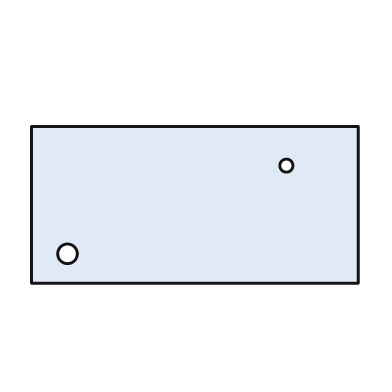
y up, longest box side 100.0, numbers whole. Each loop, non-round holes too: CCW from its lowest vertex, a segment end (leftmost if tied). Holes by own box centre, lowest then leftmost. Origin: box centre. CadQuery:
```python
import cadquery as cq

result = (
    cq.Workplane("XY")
    .moveTo(-50.0, -24.0)
    .lineTo(50.0, -24.0)
    .lineTo(50.0, 24.0)
    .lineTo(-50.0, 24.0)
    .close()
    .moveTo(-39.0, -15.0)
    .circle(3.0)
    .moveTo(28.0, 12.0)
    .circle(2.0)
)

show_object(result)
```